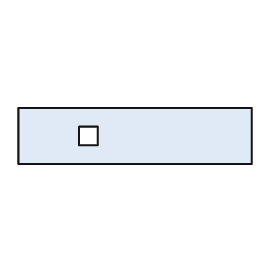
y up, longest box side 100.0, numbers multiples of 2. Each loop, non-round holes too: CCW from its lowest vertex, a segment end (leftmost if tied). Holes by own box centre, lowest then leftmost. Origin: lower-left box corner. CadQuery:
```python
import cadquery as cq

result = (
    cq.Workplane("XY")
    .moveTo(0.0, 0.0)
    .lineTo(100.0, 0.0)
    .lineTo(100.0, 24.0)
    .lineTo(0.0, 24.0)
    .close()
    .moveTo(26.0, 8.0)
    .lineTo(34.0, 8.0)
    .lineTo(34.0, 16.0)
    .lineTo(26.0, 16.0)
    .close()
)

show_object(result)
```